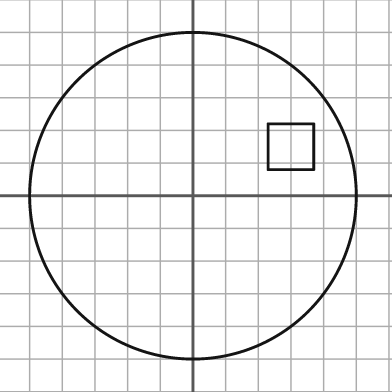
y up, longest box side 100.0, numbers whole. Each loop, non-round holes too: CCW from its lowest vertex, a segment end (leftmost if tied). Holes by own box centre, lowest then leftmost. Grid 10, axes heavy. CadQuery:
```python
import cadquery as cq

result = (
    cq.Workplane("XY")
    .moveTo(0.0, 0.0)
    .circle(50.0)
    .moveTo(23.0, 8.0)
    .lineTo(37.0, 8.0)
    .lineTo(37.0, 22.0)
    .lineTo(23.0, 22.0)
    .close()
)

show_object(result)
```